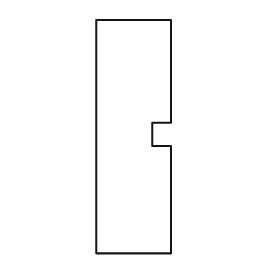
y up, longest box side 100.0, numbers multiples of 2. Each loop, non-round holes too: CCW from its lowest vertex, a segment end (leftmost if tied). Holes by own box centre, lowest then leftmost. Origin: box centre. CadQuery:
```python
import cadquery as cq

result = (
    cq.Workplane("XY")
    .moveTo(-16.0, -50.0)
    .lineTo(16.0, -50.0)
    .lineTo(16.0, -4.0)
    .lineTo(8.0, -4.0)
    .lineTo(8.0, 6.0)
    .lineTo(16.0, 6.0)
    .lineTo(16.0, 50.0)
    .lineTo(-16.0, 50.0)
    .close()
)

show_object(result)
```